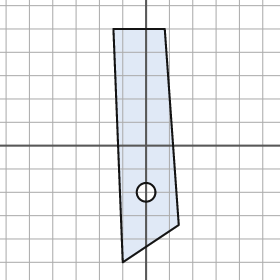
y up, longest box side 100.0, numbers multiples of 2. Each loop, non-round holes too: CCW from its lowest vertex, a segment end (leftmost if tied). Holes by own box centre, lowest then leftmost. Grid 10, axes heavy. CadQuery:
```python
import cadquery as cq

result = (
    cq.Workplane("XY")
    .moveTo(-10.0, -50.0)
    .lineTo(14.0, -34.0)
    .lineTo(8.0, 50.0)
    .lineTo(-14.0, 50.0)
    .close()
    .moveTo(0.0, -20.0)
    .circle(4.0)
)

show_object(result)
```